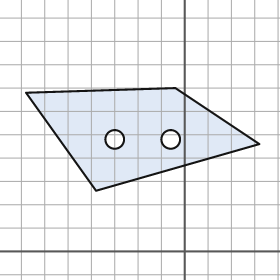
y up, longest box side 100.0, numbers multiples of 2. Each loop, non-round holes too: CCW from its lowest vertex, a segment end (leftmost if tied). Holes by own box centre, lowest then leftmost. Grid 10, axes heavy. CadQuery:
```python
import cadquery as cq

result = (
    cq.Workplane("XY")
    .moveTo(-38.0, 26.0)
    .lineTo(32.0, 46.0)
    .lineTo(-4.0, 70.0)
    .lineTo(-68.0, 68.0)
    .close()
    .moveTo(-30.0, 48.0)
    .circle(4.0)
    .moveTo(-6.0, 48.0)
    .circle(4.0)
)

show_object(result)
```